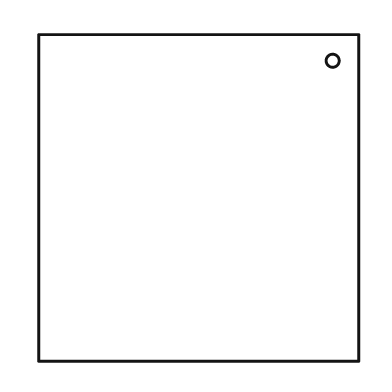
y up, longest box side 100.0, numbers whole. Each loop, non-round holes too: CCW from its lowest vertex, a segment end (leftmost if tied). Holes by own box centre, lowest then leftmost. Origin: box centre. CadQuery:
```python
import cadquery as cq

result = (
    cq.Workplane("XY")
    .moveTo(-49.0, -50.0)
    .lineTo(49.0, -50.0)
    .lineTo(49.0, 50.0)
    .lineTo(-49.0, 50.0)
    .close()
    .moveTo(41.0, 42.0)
    .circle(2.0)
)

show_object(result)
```